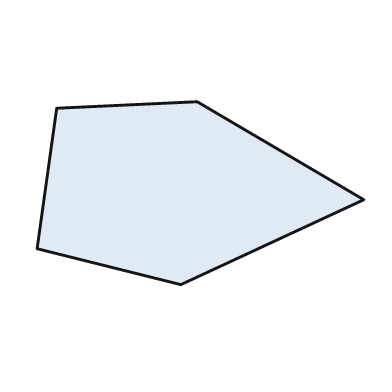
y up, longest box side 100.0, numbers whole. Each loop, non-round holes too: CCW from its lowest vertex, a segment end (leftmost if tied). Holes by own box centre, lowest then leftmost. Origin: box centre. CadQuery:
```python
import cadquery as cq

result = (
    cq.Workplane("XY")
    .moveTo(-6.0, -28.0)
    .lineTo(50.0, -2.0)
    .lineTo(-1.0, 28.0)
    .lineTo(-44.0, 26.0)
    .lineTo(-50.0, -17.0)
    .close()
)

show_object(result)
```